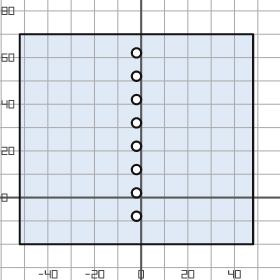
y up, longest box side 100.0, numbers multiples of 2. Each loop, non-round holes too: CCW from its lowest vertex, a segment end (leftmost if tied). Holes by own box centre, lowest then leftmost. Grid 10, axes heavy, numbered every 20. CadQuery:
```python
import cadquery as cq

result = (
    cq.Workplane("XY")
    .moveTo(-52.0, -20.0)
    .lineTo(48.0, -20.0)
    .lineTo(48.0, 70.0)
    .lineTo(-52.0, 70.0)
    .close()
    .moveTo(-2.0, -8.0)
    .circle(2.0)
    .moveTo(-2.0, 2.0)
    .circle(2.0)
    .moveTo(-2.0, 12.0)
    .circle(2.0)
    .moveTo(-2.0, 22.0)
    .circle(2.0)
    .moveTo(-2.0, 32.0)
    .circle(2.0)
    .moveTo(-2.0, 42.0)
    .circle(2.0)
    .moveTo(-2.0, 52.0)
    .circle(2.0)
    .moveTo(-2.0, 62.0)
    .circle(2.0)
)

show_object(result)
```